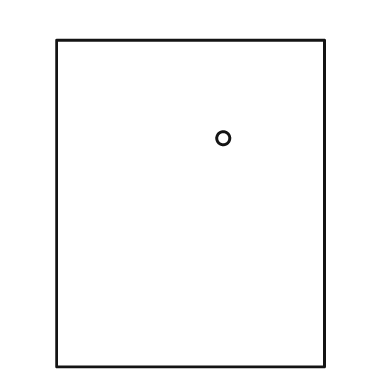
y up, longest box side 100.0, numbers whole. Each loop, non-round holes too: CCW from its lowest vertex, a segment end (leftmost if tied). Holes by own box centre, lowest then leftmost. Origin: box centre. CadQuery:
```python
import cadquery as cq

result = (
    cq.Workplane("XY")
    .moveTo(-41.0, -50.0)
    .lineTo(41.0, -50.0)
    .lineTo(41.0, 50.0)
    .lineTo(-41.0, 50.0)
    .close()
    .moveTo(10.0, 20.0)
    .circle(2.0)
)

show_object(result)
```